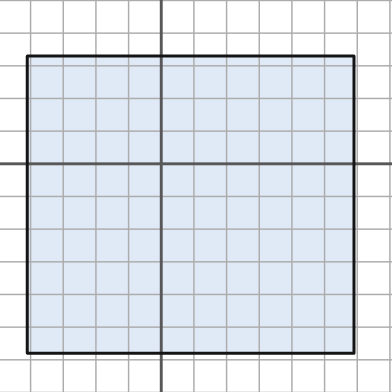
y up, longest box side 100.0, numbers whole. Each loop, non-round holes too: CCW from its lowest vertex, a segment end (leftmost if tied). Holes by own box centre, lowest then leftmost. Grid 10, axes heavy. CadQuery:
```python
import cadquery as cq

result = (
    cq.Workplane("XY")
    .moveTo(-41.0, -58.0)
    .lineTo(59.0, -58.0)
    .lineTo(59.0, 33.0)
    .lineTo(-41.0, 33.0)
    .close()
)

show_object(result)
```